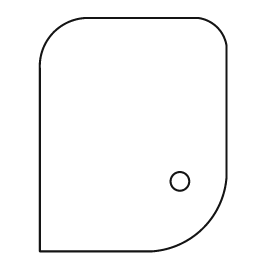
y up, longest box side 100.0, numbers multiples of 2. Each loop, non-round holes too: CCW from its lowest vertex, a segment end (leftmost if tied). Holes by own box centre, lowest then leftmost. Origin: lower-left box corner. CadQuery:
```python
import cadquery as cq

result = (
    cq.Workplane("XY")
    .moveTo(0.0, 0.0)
    .lineTo(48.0, 0.0)
    .threePointArc((70.0, 10.0), (80.0, 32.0))
    .lineTo(80.0, 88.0)
    .threePointArc((76.0, 96.0), (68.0, 100.0))
    .lineTo(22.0, 100.0)
    .threePointArc((6.0, 94.0), (0.0, 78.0))
    .close()
    .moveTo(60.0, 30.0)
    .circle(4.0)
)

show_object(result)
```